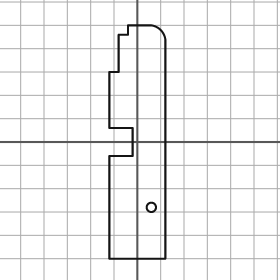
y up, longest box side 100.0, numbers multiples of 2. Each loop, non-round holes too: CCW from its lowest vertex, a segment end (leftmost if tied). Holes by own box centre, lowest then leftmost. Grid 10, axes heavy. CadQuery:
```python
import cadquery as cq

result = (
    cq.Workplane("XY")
    .moveTo(-12.0, -50.0)
    .lineTo(12.0, -50.0)
    .lineTo(12.0, 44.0)
    .threePointArc((10.0, 48.0), (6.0, 50.0))
    .lineTo(-4.0, 50.0)
    .lineTo(-4.0, 46.0)
    .lineTo(-8.0, 46.0)
    .lineTo(-8.0, 30.0)
    .lineTo(-12.0, 30.0)
    .lineTo(-12.0, 6.0)
    .lineTo(-2.0, 6.0)
    .lineTo(-2.0, -6.0)
    .lineTo(-12.0, -6.0)
    .close()
    .moveTo(6.0, -28.0)
    .circle(2.0)
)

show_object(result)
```